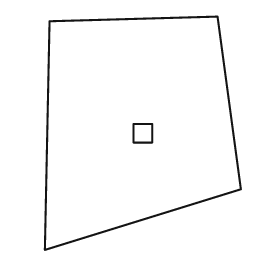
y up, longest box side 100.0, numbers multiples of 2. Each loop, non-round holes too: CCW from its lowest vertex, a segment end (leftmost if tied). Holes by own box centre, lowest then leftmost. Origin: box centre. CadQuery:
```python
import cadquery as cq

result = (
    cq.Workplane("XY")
    .moveTo(-42.0, -50.0)
    .lineTo(42.0, -24.0)
    .lineTo(32.0, 50.0)
    .lineTo(-40.0, 48.0)
    .close()
    .moveTo(-4.0, -4.0)
    .lineTo(4.0, -4.0)
    .lineTo(4.0, 4.0)
    .lineTo(-4.0, 4.0)
    .close()
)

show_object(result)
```